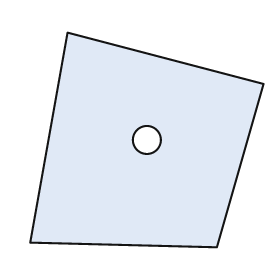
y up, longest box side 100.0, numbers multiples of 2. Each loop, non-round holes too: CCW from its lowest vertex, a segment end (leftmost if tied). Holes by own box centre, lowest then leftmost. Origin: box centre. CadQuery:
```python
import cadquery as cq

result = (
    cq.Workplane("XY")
    .moveTo(30.0, -46.0)
    .lineTo(50.0, 24.0)
    .lineTo(-34.0, 46.0)
    .lineTo(-50.0, -44.0)
    .close()
    .moveTo(0.0, 0.0)
    .circle(6.0)
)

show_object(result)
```